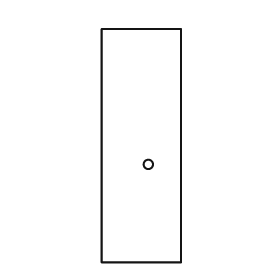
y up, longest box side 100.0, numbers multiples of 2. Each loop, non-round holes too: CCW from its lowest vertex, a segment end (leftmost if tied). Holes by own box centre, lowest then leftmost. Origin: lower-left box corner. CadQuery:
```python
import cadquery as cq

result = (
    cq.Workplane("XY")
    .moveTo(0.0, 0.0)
    .lineTo(34.0, 0.0)
    .lineTo(34.0, 100.0)
    .lineTo(0.0, 100.0)
    .close()
    .moveTo(20.0, 42.0)
    .circle(2.0)
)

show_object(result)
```